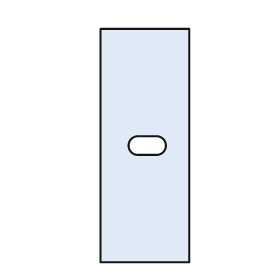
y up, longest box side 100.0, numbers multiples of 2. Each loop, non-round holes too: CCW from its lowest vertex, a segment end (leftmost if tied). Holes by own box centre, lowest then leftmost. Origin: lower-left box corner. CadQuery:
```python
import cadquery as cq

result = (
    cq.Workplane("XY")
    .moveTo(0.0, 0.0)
    .lineTo(38.0, 0.0)
    .lineTo(38.0, 100.0)
    .lineTo(0.0, 100.0)
    .close()
    .moveTo(16.0, 46.0)
    .lineTo(24.0, 46.0)
    .threePointArc((28.0, 50.0), (24.0, 54.0))
    .lineTo(16.0, 54.0)
    .threePointArc((12.0, 50.0), (16.0, 46.0))
    .close()
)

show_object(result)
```